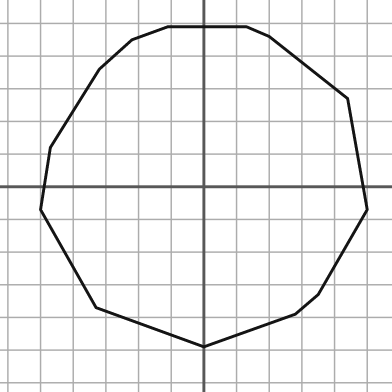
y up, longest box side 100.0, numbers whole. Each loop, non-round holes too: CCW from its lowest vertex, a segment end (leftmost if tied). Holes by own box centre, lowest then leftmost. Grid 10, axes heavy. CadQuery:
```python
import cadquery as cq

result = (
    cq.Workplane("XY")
    .moveTo(0.0, -49.0)
    .lineTo(28.0, -39.0)
    .lineTo(35.0, -33.0)
    .lineTo(50.0, -7.0)
    .lineTo(44.0, 27.0)
    .lineTo(20.0, 46.0)
    .lineTo(13.0, 49.0)
    .lineTo(-11.0, 49.0)
    .lineTo(-22.0, 45.0)
    .lineTo(-32.0, 36.0)
    .lineTo(-47.0, 12.0)
    .lineTo(-50.0, -7.0)
    .lineTo(-33.0, -37.0)
    .close()
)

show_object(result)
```